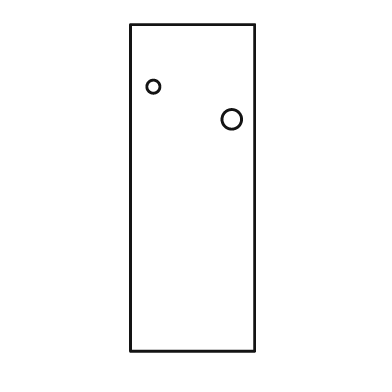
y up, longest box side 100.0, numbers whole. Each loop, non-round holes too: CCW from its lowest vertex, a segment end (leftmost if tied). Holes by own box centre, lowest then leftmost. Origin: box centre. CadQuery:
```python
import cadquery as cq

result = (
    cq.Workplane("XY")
    .moveTo(-19.0, -50.0)
    .lineTo(19.0, -50.0)
    .lineTo(19.0, 50.0)
    .lineTo(-19.0, 50.0)
    .close()
    .moveTo(12.0, 21.0)
    .circle(3.0)
    .moveTo(-12.0, 31.0)
    .circle(2.0)
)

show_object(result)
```